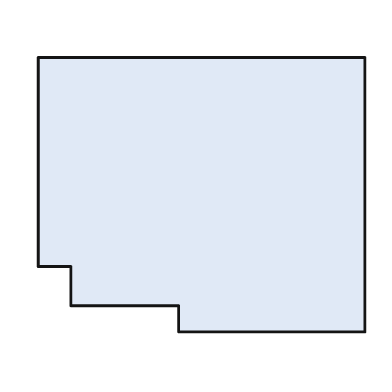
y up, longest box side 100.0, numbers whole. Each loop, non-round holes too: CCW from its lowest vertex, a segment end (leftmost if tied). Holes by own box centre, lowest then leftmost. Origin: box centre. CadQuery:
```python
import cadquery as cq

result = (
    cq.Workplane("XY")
    .moveTo(-7.0, -42.0)
    .lineTo(50.0, -42.0)
    .lineTo(50.0, 42.0)
    .lineTo(-50.0, 42.0)
    .lineTo(-50.0, -22.0)
    .lineTo(-40.0, -22.0)
    .lineTo(-40.0, -34.0)
    .lineTo(-7.0, -34.0)
    .close()
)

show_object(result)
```